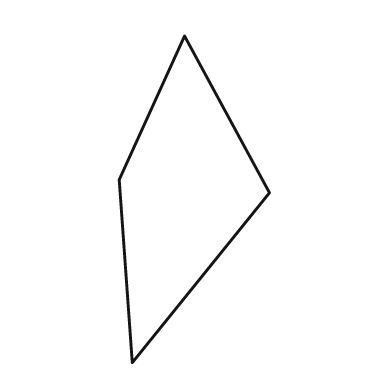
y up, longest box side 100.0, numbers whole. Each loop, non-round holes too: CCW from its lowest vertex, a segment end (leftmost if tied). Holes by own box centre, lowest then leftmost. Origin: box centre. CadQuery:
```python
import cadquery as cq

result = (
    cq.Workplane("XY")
    .moveTo(-19.0, -50.0)
    .lineTo(23.0, 2.0)
    .lineTo(-3.0, 50.0)
    .lineTo(-23.0, 6.0)
    .close()
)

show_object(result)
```